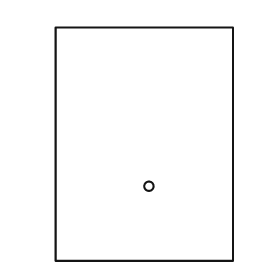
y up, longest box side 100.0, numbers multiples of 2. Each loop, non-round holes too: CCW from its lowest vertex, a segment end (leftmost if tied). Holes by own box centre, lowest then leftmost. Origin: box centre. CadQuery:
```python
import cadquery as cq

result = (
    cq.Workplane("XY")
    .moveTo(-38.0, -50.0)
    .lineTo(38.0, -50.0)
    .lineTo(38.0, 50.0)
    .lineTo(-38.0, 50.0)
    .close()
    .moveTo(2.0, -18.0)
    .circle(2.0)
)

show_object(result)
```